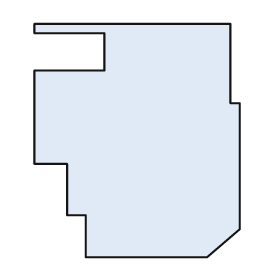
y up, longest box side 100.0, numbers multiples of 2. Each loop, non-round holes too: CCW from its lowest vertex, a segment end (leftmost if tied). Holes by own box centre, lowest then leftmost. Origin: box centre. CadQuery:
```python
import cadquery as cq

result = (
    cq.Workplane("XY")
    .moveTo(-22.0, -50.0)
    .lineTo(30.0, -50.0)
    .lineTo(44.0, -38.0)
    .lineTo(44.0, 16.0)
    .lineTo(40.0, 16.0)
    .lineTo(40.0, 50.0)
    .lineTo(-44.0, 50.0)
    .lineTo(-44.0, 46.0)
    .lineTo(-14.0, 46.0)
    .lineTo(-14.0, 30.0)
    .lineTo(-44.0, 30.0)
    .lineTo(-44.0, -10.0)
    .lineTo(-30.0, -10.0)
    .lineTo(-30.0, -32.0)
    .lineTo(-22.0, -32.0)
    .close()
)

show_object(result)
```